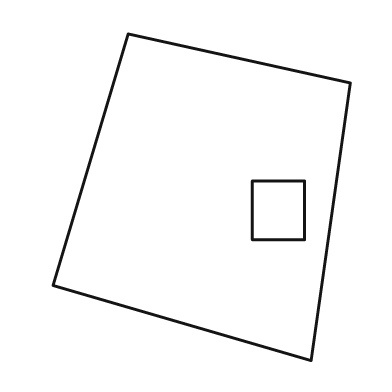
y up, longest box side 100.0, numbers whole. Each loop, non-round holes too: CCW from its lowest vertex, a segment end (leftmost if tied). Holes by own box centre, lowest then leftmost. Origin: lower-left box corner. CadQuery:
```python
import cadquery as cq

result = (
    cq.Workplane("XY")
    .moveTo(79.0, 0.0)
    .lineTo(91.0, 85.0)
    .lineTo(23.0, 100.0)
    .lineTo(0.0, 23.0)
    .close()
    .moveTo(61.0, 37.0)
    .lineTo(77.0, 37.0)
    .lineTo(77.0, 55.0)
    .lineTo(61.0, 55.0)
    .close()
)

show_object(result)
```